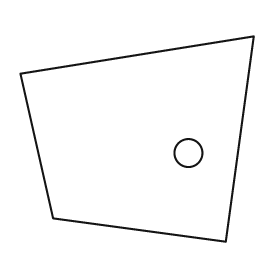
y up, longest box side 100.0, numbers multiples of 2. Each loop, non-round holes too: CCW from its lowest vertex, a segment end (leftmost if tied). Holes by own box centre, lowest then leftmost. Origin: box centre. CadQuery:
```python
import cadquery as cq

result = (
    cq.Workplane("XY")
    .moveTo(38.0, -44.0)
    .lineTo(50.0, 44.0)
    .lineTo(-50.0, 28.0)
    .lineTo(-36.0, -34.0)
    .close()
    .moveTo(22.0, -6.0)
    .circle(6.0)
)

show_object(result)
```